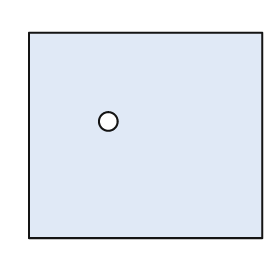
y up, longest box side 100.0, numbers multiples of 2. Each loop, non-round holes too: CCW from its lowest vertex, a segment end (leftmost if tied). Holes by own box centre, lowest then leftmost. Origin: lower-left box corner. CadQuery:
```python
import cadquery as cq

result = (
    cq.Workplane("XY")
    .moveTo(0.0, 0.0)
    .lineTo(100.0, 0.0)
    .lineTo(100.0, 88.0)
    .lineTo(0.0, 88.0)
    .close()
    .moveTo(34.0, 50.0)
    .circle(4.0)
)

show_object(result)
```